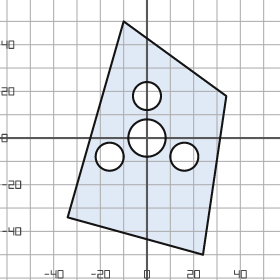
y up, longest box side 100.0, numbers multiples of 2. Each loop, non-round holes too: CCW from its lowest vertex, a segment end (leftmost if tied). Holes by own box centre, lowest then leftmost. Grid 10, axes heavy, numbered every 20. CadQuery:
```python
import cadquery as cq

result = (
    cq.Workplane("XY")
    .moveTo(24.0, -50.0)
    .lineTo(34.0, 18.0)
    .lineTo(-10.0, 50.0)
    .lineTo(-34.0, -34.0)
    .close()
    .moveTo(-16.0, -8.0)
    .circle(6.0)
    .moveTo(16.0, -8.0)
    .circle(6.0)
    .moveTo(0.0, 0.0)
    .circle(8.0)
    .moveTo(0.0, 18.0)
    .circle(6.0)
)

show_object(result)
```